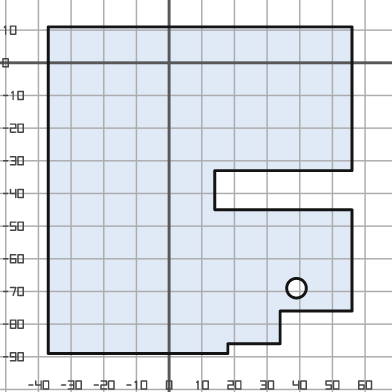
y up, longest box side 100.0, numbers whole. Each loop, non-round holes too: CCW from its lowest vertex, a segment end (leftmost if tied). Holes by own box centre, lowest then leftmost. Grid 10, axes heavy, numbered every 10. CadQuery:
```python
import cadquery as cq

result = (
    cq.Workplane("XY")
    .moveTo(-37.0, -89.0)
    .lineTo(18.0, -89.0)
    .lineTo(18.0, -86.0)
    .lineTo(34.0, -86.0)
    .lineTo(34.0, -76.0)
    .lineTo(56.0, -76.0)
    .lineTo(56.0, -45.0)
    .lineTo(14.0, -45.0)
    .lineTo(14.0, -33.0)
    .lineTo(56.0, -33.0)
    .lineTo(56.0, 11.0)
    .lineTo(-37.0, 11.0)
    .close()
    .moveTo(39.0, -69.0)
    .circle(3.0)
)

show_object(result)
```